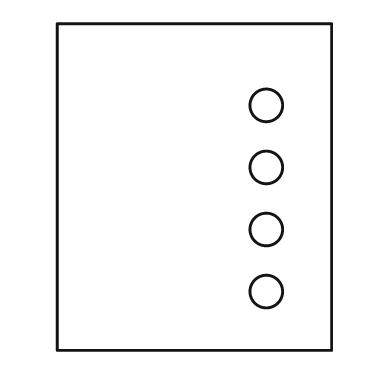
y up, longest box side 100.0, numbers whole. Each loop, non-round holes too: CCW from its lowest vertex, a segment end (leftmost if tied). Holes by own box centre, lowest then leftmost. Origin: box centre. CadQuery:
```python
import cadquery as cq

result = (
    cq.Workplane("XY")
    .moveTo(-42.0, -50.0)
    .lineTo(42.0, -50.0)
    .lineTo(42.0, 50.0)
    .lineTo(-42.0, 50.0)
    .close()
    .moveTo(22.0, -32.0)
    .circle(5.0)
    .moveTo(22.0, -13.0)
    .circle(5.0)
    .moveTo(22.0, 6.0)
    .circle(5.0)
    .moveTo(22.0, 25.0)
    .circle(5.0)
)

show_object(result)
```